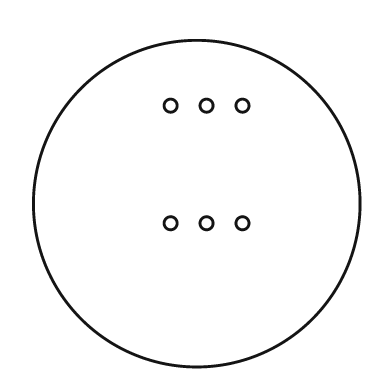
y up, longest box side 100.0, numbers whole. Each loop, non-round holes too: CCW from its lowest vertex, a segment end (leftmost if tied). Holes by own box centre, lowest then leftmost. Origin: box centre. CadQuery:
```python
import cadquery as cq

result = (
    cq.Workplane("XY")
    .moveTo(0.0, 0.0)
    .circle(50.0)
    .moveTo(-8.0, -6.0)
    .circle(2.0)
    .moveTo(3.0, -6.0)
    .circle(2.0)
    .moveTo(14.0, -6.0)
    .circle(2.0)
    .moveTo(-8.0, 30.0)
    .circle(2.0)
    .moveTo(3.0, 30.0)
    .circle(2.0)
    .moveTo(14.0, 30.0)
    .circle(2.0)
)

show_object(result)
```